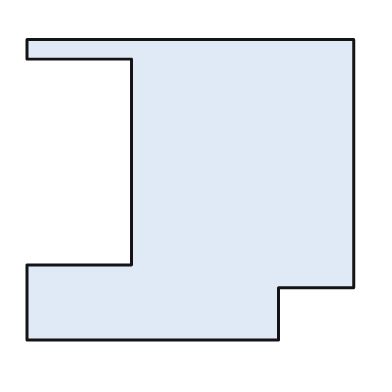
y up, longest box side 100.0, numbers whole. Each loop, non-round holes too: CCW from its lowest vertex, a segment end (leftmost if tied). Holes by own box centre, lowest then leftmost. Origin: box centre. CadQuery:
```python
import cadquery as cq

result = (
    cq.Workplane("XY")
    .moveTo(-50.0, -46.0)
    .lineTo(27.0, -46.0)
    .lineTo(27.0, -30.0)
    .lineTo(50.0, -30.0)
    .lineTo(50.0, 46.0)
    .lineTo(-50.0, 46.0)
    .lineTo(-50.0, 40.0)
    .lineTo(-18.0, 40.0)
    .lineTo(-18.0, -23.0)
    .lineTo(-50.0, -23.0)
    .close()
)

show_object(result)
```